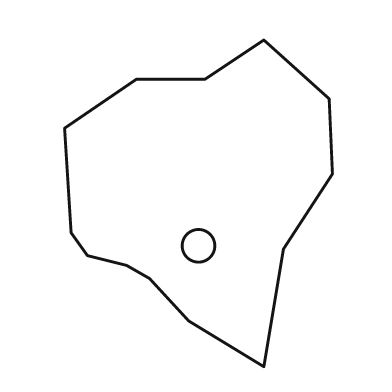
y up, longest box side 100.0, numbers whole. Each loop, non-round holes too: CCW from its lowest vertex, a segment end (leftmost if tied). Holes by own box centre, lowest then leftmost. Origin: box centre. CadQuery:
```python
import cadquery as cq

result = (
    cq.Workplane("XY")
    .moveTo(20.0, -50.0)
    .lineTo(26.0, -14.0)
    .lineTo(41.0, 9.0)
    .lineTo(40.0, 32.0)
    .lineTo(20.0, 50.0)
    .lineTo(2.0, 38.0)
    .lineTo(-19.0, 38.0)
    .lineTo(-41.0, 23.0)
    .lineTo(-39.0, -9.0)
    .lineTo(-34.0, -16.0)
    .lineTo(-22.0, -19.0)
    .lineTo(-15.0, -23.0)
    .lineTo(-3.0, -36.0)
    .close()
    .moveTo(0.0, -13.0)
    .circle(5.0)
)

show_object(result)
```